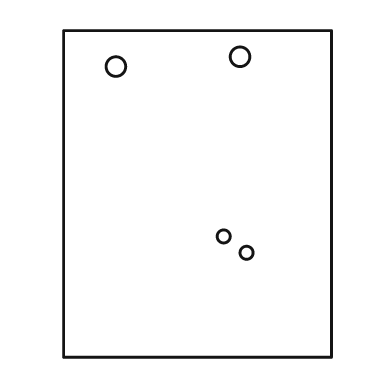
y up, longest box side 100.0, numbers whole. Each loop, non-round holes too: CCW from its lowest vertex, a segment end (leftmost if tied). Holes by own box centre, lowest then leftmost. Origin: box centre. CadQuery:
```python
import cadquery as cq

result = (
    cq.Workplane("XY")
    .moveTo(-41.0, -50.0)
    .lineTo(41.0, -50.0)
    .lineTo(41.0, 50.0)
    .lineTo(-41.0, 50.0)
    .close()
    .moveTo(15.0, -18.0)
    .circle(2.0)
    .moveTo(8.0, -13.0)
    .circle(2.0)
    .moveTo(-25.0, 39.0)
    .circle(3.0)
    .moveTo(13.0, 42.0)
    .circle(3.0)
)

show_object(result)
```